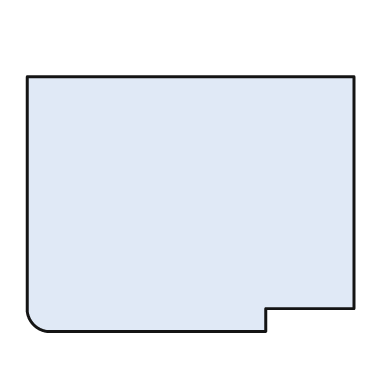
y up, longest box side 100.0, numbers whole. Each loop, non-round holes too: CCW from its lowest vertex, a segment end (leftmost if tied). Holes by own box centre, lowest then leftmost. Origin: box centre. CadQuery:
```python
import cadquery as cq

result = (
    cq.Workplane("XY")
    .moveTo(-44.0, -39.0)
    .lineTo(23.0, -39.0)
    .lineTo(23.0, -32.0)
    .lineTo(50.0, -32.0)
    .lineTo(50.0, 39.0)
    .lineTo(-50.0, 39.0)
    .lineTo(-50.0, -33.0)
    .threePointArc((-48.0, -37.0), (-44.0, -39.0))
    .close()
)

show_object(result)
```